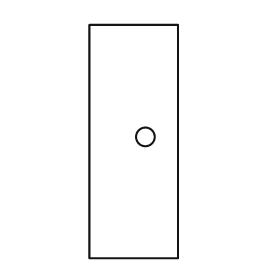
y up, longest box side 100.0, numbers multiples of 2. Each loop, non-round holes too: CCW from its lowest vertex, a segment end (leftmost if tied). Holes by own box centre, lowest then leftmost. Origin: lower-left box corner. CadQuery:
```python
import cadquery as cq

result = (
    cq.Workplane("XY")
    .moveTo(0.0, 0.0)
    .lineTo(38.0, 0.0)
    .lineTo(38.0, 100.0)
    .lineTo(0.0, 100.0)
    .close()
    .moveTo(24.0, 52.0)
    .circle(4.0)
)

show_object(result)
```